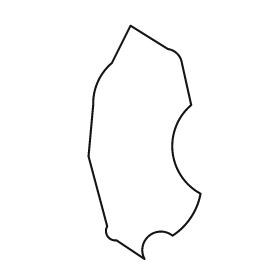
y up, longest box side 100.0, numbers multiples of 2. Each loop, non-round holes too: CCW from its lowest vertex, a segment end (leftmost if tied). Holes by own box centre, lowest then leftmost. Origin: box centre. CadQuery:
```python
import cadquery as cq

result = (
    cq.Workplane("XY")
    .moveTo(0.0, -50.0)
    .threePointArc((2.0, -40.0), (12.0, -40.0))
    .threePointArc((20.0, -32.0), (24.0, -22.0))
    .threePointArc((12.0, -4.0), (20.0, 16.0))
    .lineTo(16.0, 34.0)
    .threePointArc((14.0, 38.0), (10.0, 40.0))
    .lineTo(-6.0, 50.0)
    .lineTo(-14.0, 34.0)
    .threePointArc((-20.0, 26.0), (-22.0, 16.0))
    .lineTo(-24.0, -6.0)
    .lineTo(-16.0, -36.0)
    .threePointArc((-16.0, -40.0), (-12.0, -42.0))
    .close()
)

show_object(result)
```